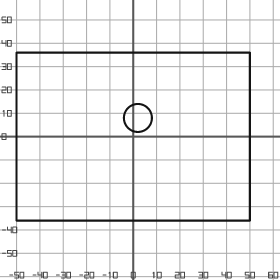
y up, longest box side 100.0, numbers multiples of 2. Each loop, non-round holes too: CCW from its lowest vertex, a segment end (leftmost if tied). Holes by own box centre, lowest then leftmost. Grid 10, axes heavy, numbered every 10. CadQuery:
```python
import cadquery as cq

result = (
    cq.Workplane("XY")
    .moveTo(-50.0, -36.0)
    .lineTo(50.0, -36.0)
    .lineTo(50.0, 36.0)
    .lineTo(-50.0, 36.0)
    .close()
    .moveTo(2.0, 8.0)
    .circle(6.0)
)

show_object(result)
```